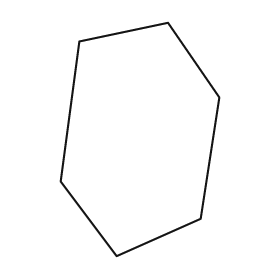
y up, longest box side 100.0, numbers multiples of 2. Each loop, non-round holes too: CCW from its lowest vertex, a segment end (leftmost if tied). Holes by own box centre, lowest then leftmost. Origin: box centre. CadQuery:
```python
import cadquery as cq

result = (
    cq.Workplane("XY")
    .moveTo(-10.0, -50.0)
    .lineTo(26.0, -34.0)
    .lineTo(34.0, 18.0)
    .lineTo(12.0, 50.0)
    .lineTo(-26.0, 42.0)
    .lineTo(-34.0, -18.0)
    .close()
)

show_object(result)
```